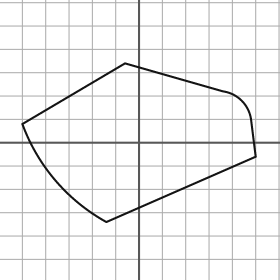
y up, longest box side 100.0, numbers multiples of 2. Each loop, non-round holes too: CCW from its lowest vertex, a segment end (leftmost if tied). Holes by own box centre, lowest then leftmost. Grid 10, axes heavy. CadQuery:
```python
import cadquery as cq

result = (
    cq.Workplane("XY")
    .moveTo(-14.0, -34.0)
    .lineTo(50.0, -6.0)
    .lineTo(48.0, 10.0)
    .threePointArc((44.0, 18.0), (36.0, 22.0))
    .lineTo(-6.0, 34.0)
    .lineTo(-50.0, 8.0)
    .threePointArc((-36.0, -16.0), (-14.0, -34.0))
    .close()
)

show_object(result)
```